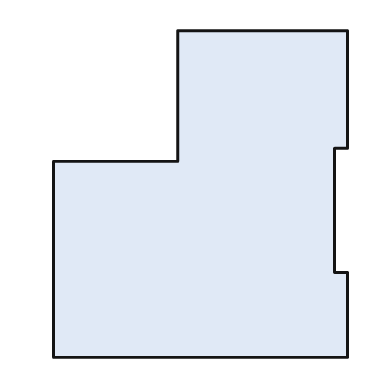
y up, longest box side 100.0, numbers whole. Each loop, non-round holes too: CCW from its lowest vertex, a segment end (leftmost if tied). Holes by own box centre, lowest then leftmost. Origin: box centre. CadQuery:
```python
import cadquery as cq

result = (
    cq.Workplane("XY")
    .moveTo(-45.0, -50.0)
    .lineTo(45.0, -50.0)
    .lineTo(45.0, -24.0)
    .lineTo(41.0, -24.0)
    .lineTo(41.0, 14.0)
    .lineTo(45.0, 14.0)
    .lineTo(45.0, 50.0)
    .lineTo(-7.0, 50.0)
    .lineTo(-7.0, 10.0)
    .lineTo(-45.0, 10.0)
    .close()
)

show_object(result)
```